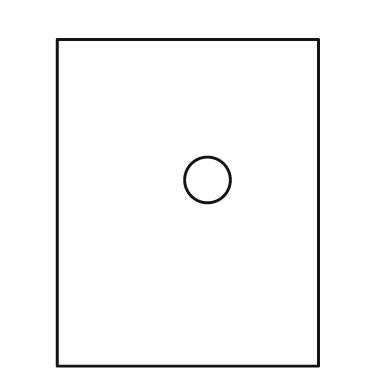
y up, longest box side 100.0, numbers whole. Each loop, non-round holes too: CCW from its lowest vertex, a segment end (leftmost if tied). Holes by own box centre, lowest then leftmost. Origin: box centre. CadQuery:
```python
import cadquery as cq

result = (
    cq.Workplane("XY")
    .moveTo(-40.0, -50.0)
    .lineTo(40.0, -50.0)
    .lineTo(40.0, 50.0)
    .lineTo(-40.0, 50.0)
    .close()
    .moveTo(6.0, 7.0)
    .circle(7.0)
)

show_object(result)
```